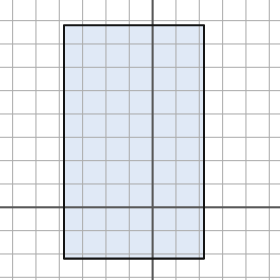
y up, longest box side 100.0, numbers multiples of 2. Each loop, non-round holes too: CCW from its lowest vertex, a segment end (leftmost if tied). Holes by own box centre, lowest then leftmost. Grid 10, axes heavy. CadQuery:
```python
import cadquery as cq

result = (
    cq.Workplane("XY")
    .moveTo(-38.0, -22.0)
    .lineTo(22.0, -22.0)
    .lineTo(22.0, 78.0)
    .lineTo(-38.0, 78.0)
    .close()
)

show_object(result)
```